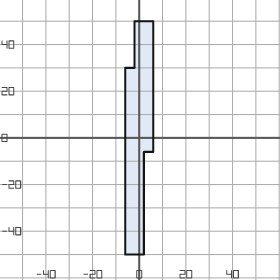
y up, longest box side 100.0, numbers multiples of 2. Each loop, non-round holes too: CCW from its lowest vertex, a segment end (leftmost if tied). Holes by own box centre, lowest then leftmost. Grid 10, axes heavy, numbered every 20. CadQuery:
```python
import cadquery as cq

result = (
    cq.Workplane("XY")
    .moveTo(-6.0, -50.0)
    .lineTo(2.0, -50.0)
    .lineTo(2.0, -6.0)
    .lineTo(6.0, -6.0)
    .lineTo(6.0, 50.0)
    .lineTo(-2.0, 50.0)
    .lineTo(-2.0, 30.0)
    .lineTo(-6.0, 30.0)
    .close()
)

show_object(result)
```